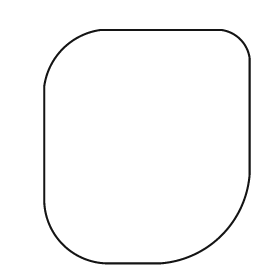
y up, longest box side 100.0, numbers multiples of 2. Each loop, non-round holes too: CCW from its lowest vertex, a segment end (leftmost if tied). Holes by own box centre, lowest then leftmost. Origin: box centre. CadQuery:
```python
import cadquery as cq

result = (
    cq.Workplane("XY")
    .moveTo(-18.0, -50.0)
    .lineTo(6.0, -50.0)
    .threePointArc((32.0, -38.0), (44.0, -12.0))
    .lineTo(44.0, 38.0)
    .threePointArc((40.0, 46.0), (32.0, 50.0))
    .lineTo(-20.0, 50.0)
    .threePointArc((-36.0, 42.0), (-44.0, 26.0))
    .lineTo(-44.0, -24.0)
    .threePointArc((-36.0, -42.0), (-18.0, -50.0))
    .close()
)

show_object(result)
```